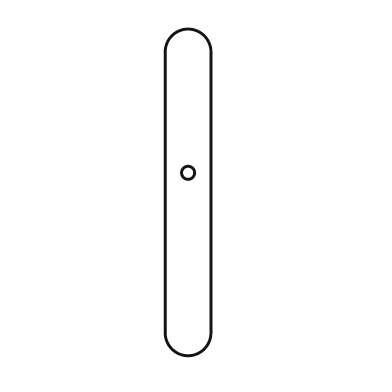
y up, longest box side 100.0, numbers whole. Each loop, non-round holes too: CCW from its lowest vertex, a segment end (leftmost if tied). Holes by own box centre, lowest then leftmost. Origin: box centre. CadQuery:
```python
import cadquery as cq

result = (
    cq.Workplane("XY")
    .moveTo(-7.0, -43.0)
    .threePointArc((0.0, -50.0), (7.0, -43.0))
    .lineTo(7.0, 43.0)
    .threePointArc((0.0, 50.0), (-7.0, 43.0))
    .close()
    .moveTo(0.0, 6.0)
    .circle(2.0)
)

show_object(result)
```